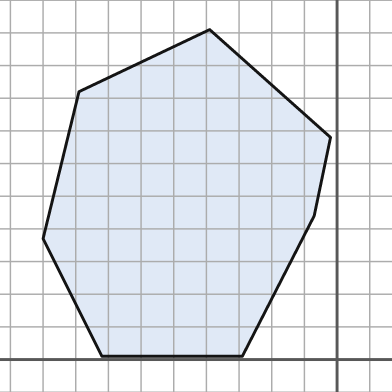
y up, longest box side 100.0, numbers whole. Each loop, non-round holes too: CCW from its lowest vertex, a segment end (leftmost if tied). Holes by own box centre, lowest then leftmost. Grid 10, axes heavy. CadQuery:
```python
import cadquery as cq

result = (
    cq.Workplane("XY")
    .moveTo(-72.0, 1.0)
    .lineTo(-29.0, 1.0)
    .lineTo(-7.0, 44.0)
    .lineTo(-2.0, 68.0)
    .lineTo(-39.0, 101.0)
    .lineTo(-79.0, 82.0)
    .lineTo(-90.0, 37.0)
    .close()
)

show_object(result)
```